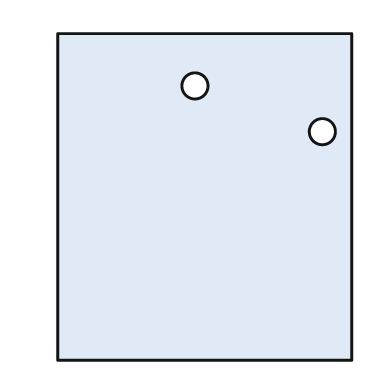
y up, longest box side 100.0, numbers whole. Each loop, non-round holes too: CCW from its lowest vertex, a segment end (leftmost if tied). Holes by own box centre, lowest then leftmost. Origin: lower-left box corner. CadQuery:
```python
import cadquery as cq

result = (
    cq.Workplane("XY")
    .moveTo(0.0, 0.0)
    .lineTo(90.0, 0.0)
    .lineTo(90.0, 100.0)
    .lineTo(0.0, 100.0)
    .close()
    .moveTo(81.0, 70.0)
    .circle(4.0)
    .moveTo(42.0, 84.0)
    .circle(4.0)
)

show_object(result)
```